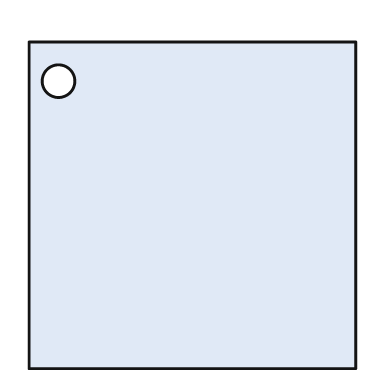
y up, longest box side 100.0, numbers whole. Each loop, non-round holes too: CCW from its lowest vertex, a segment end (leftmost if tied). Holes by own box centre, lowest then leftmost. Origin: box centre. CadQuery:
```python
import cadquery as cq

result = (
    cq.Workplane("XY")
    .moveTo(-50.0, -50.0)
    .lineTo(50.0, -50.0)
    .lineTo(50.0, 50.0)
    .lineTo(-50.0, 50.0)
    .close()
    .moveTo(-41.0, 38.0)
    .circle(5.0)
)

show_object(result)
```